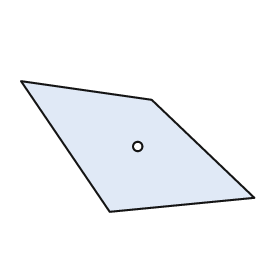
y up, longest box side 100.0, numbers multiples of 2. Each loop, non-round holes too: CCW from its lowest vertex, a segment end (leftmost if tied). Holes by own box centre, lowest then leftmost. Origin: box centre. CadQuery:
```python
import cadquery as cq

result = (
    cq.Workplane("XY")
    .moveTo(-12.0, -28.0)
    .lineTo(50.0, -22.0)
    .lineTo(6.0, 20.0)
    .lineTo(-50.0, 28.0)
    .close()
    .moveTo(0.0, 0.0)
    .circle(2.0)
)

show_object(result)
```